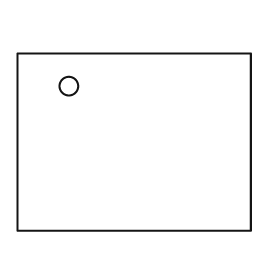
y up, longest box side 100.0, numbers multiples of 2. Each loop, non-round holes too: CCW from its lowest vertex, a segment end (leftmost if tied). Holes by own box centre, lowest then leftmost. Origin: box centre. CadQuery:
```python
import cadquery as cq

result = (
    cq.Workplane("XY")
    .moveTo(-50.0, -38.0)
    .lineTo(50.0, -38.0)
    .lineTo(50.0, 38.0)
    .lineTo(-50.0, 38.0)
    .close()
    .moveTo(-28.0, 24.0)
    .circle(4.0)
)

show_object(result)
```